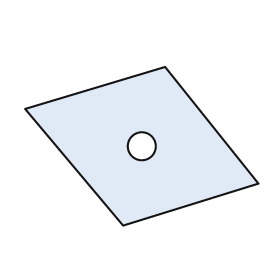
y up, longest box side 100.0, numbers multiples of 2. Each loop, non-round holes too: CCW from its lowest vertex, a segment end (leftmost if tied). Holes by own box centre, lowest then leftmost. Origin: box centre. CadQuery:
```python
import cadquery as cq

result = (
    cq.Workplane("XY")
    .moveTo(-8.0, -34.0)
    .lineTo(50.0, -16.0)
    .lineTo(10.0, 34.0)
    .lineTo(-50.0, 16.0)
    .close()
    .moveTo(0.0, 0.0)
    .circle(6.0)
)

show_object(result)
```